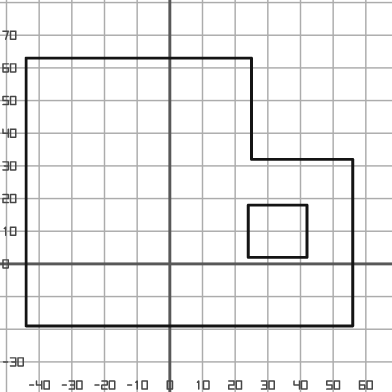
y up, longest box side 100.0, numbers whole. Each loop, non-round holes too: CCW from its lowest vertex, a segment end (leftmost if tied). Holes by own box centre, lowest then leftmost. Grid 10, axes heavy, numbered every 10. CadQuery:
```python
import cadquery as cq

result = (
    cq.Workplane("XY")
    .moveTo(-44.0, -19.0)
    .lineTo(56.0, -19.0)
    .lineTo(56.0, 32.0)
    .lineTo(25.0, 32.0)
    .lineTo(25.0, 63.0)
    .lineTo(-44.0, 63.0)
    .close()
    .moveTo(24.0, 2.0)
    .lineTo(42.0, 2.0)
    .lineTo(42.0, 18.0)
    .lineTo(24.0, 18.0)
    .close()
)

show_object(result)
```